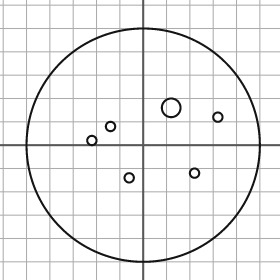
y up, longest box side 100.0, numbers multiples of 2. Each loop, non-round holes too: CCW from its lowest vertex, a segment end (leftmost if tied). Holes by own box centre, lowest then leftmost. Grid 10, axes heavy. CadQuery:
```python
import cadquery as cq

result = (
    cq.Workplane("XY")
    .moveTo(0.0, 0.0)
    .circle(50.0)
    .moveTo(-6.0, -14.0)
    .circle(2.0)
    .moveTo(22.0, -12.0)
    .circle(2.0)
    .moveTo(-22.0, 2.0)
    .circle(2.0)
    .moveTo(-14.0, 8.0)
    .circle(2.0)
    .moveTo(32.0, 12.0)
    .circle(2.0)
    .moveTo(12.0, 16.0)
    .circle(4.0)
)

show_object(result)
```